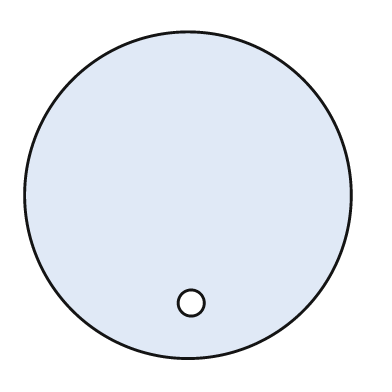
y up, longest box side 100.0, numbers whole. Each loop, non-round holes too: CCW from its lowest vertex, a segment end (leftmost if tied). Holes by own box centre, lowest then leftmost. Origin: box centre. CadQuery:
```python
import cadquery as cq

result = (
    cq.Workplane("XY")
    .moveTo(0.0, 0.0)
    .circle(50.0)
    .moveTo(1.0, -33.0)
    .circle(4.0)
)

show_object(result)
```